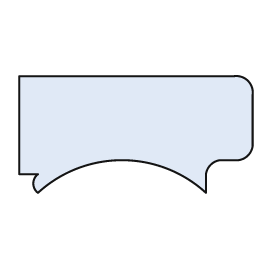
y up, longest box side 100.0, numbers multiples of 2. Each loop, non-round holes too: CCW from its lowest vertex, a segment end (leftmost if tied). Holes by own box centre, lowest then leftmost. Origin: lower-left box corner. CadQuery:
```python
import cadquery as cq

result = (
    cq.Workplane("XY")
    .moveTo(8.0, 0.0)
    .threePointArc((44.0, 14.0), (80.0, 0.0))
    .lineTo(80.0, 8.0)
    .threePointArc((82.0, 12.0), (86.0, 14.0))
    .lineTo(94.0, 14.0)
    .threePointArc((98.0, 16.0), (100.0, 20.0))
    .lineTo(100.0, 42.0)
    .threePointArc((98.0, 48.0), (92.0, 50.0))
    .lineTo(0.0, 50.0)
    .lineTo(0.0, 8.0)
    .lineTo(8.0, 8.0)
    .threePointArc((6.0, 4.0), (8.0, 0.0))
    .close()
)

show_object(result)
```